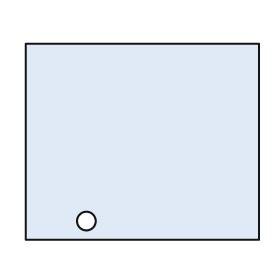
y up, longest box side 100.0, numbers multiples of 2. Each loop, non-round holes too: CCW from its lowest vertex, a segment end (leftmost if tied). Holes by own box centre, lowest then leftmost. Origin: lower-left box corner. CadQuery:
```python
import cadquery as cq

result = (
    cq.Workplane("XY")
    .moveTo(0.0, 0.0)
    .lineTo(100.0, 0.0)
    .lineTo(100.0, 84.0)
    .lineTo(0.0, 84.0)
    .close()
    .moveTo(26.0, 8.0)
    .circle(4.0)
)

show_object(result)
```